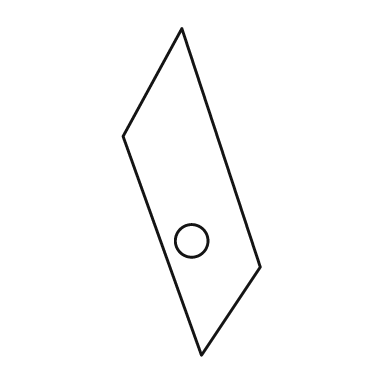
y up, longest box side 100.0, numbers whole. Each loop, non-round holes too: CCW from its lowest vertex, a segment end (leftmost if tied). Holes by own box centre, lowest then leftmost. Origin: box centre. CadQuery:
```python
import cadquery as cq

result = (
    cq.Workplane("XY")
    .moveTo(3.0, -50.0)
    .lineTo(21.0, -23.0)
    .lineTo(-3.0, 50.0)
    .lineTo(-21.0, 17.0)
    .close()
    .moveTo(0.0, -15.0)
    .circle(5.0)
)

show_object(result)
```